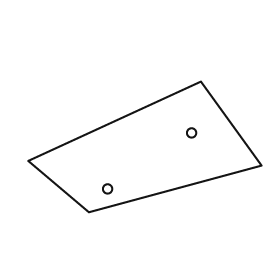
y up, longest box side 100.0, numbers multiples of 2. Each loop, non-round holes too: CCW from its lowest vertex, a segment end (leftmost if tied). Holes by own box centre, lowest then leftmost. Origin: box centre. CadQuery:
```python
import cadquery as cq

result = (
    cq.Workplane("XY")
    .moveTo(-24.0, -28.0)
    .lineTo(50.0, -8.0)
    .lineTo(24.0, 28.0)
    .lineTo(-50.0, -6.0)
    .close()
    .moveTo(-16.0, -18.0)
    .circle(2.0)
    .moveTo(20.0, 6.0)
    .circle(2.0)
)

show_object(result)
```